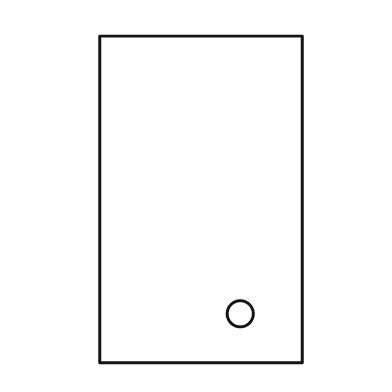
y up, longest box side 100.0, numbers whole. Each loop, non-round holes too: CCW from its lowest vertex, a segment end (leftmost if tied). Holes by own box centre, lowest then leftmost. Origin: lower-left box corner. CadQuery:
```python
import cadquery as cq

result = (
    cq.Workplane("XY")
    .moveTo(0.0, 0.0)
    .lineTo(62.0, 0.0)
    .lineTo(62.0, 100.0)
    .lineTo(0.0, 100.0)
    .close()
    .moveTo(43.0, 15.0)
    .circle(4.0)
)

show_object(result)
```